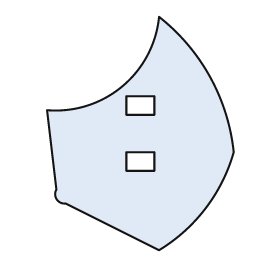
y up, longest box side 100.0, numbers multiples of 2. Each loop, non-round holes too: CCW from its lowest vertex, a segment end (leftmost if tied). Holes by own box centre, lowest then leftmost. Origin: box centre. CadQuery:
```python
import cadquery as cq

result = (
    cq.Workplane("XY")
    .moveTo(8.0, -50.0)
    .threePointArc((28.0, -32.0), (40.0, -8.0))
    .threePointArc((30.0, 24.0), (8.0, 50.0))
    .threePointArc((-8.0, 20.0), (-40.0, 10.0))
    .lineTo(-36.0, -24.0)
    .threePointArc((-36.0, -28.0), (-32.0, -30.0))
    .close()
    .moveTo(-6.0, -16.0)
    .lineTo(6.0, -16.0)
    .lineTo(6.0, -8.0)
    .lineTo(-6.0, -8.0)
    .close()
    .moveTo(-6.0, 8.0)
    .lineTo(6.0, 8.0)
    .lineTo(6.0, 16.0)
    .lineTo(-6.0, 16.0)
    .close()
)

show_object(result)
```